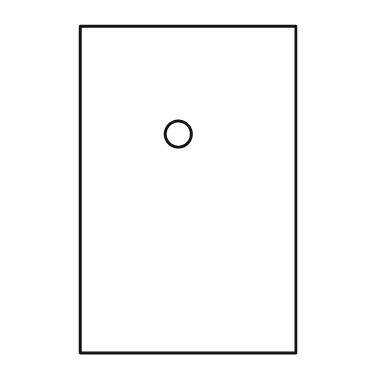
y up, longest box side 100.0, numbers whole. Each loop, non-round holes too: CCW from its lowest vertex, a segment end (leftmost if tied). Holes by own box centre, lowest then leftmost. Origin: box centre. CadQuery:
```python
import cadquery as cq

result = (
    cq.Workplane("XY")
    .moveTo(-33.0, -50.0)
    .lineTo(33.0, -50.0)
    .lineTo(33.0, 50.0)
    .lineTo(-33.0, 50.0)
    .close()
    .moveTo(-3.0, 17.0)
    .circle(4.0)
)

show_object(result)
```